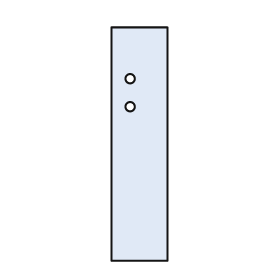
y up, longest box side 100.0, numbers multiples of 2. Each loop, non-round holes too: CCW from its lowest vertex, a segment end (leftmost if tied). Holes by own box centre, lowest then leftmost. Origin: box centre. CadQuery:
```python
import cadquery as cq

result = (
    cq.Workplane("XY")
    .moveTo(-12.0, -50.0)
    .lineTo(12.0, -50.0)
    .lineTo(12.0, 50.0)
    .lineTo(-12.0, 50.0)
    .close()
    .moveTo(-4.0, 16.0)
    .circle(2.0)
    .moveTo(-4.0, 28.0)
    .circle(2.0)
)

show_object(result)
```